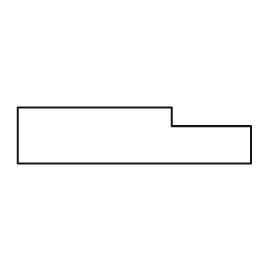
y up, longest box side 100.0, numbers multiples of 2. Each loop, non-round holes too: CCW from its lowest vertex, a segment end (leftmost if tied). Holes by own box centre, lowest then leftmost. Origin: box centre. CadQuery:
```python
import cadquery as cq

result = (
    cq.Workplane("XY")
    .moveTo(-50.0, -12.0)
    .lineTo(50.0, -12.0)
    .lineTo(50.0, 4.0)
    .lineTo(16.0, 4.0)
    .lineTo(16.0, 12.0)
    .lineTo(-50.0, 12.0)
    .close()
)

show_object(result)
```